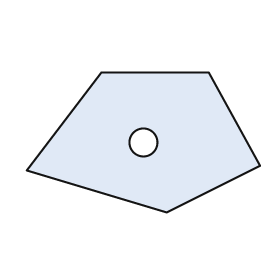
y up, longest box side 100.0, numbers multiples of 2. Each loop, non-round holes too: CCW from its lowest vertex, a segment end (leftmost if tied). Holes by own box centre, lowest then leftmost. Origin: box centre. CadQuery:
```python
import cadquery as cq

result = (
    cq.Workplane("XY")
    .moveTo(10.0, -30.0)
    .lineTo(50.0, -10.0)
    .lineTo(28.0, 30.0)
    .lineTo(-18.0, 30.0)
    .lineTo(-50.0, -12.0)
    .close()
    .moveTo(0.0, 0.0)
    .circle(6.0)
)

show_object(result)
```